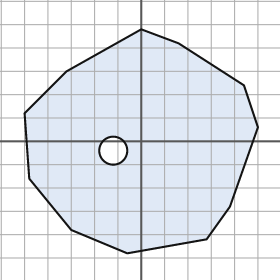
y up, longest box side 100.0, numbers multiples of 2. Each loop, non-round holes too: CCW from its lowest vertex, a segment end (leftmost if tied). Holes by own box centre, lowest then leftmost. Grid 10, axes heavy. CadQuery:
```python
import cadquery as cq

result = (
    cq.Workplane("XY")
    .moveTo(-6.0, -48.0)
    .lineTo(28.0, -42.0)
    .lineTo(38.0, -28.0)
    .lineTo(50.0, 6.0)
    .lineTo(44.0, 24.0)
    .lineTo(16.0, 42.0)
    .lineTo(0.0, 48.0)
    .lineTo(-32.0, 30.0)
    .lineTo(-50.0, 12.0)
    .lineTo(-48.0, -16.0)
    .lineTo(-30.0, -38.0)
    .close()
    .moveTo(-12.0, -4.0)
    .circle(6.0)
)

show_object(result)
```